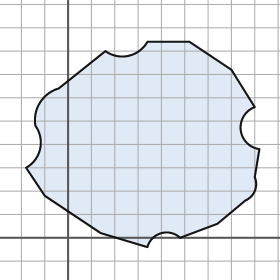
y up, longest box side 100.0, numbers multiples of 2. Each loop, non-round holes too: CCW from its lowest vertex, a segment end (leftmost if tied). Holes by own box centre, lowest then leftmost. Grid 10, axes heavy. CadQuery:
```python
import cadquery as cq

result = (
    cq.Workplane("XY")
    .moveTo(34.0, -4.0)
    .threePointArc((40.0, 2.0), (48.0, 0.0))
    .lineTo(64.0, 6.0)
    .lineTo(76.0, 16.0)
    .threePointArc((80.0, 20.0), (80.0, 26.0))
    .lineTo(82.0, 38.0)
    .threePointArc((74.0, 46.0), (80.0, 56.0))
    .lineTo(70.0, 72.0)
    .lineTo(52.0, 84.0)
    .lineTo(34.0, 84.0)
    .threePointArc((26.0, 78.0), (16.0, 80.0))
    .lineTo(-4.0, 64.0)
    .threePointArc((-12.0, 58.0), (-14.0, 48.0))
    .threePointArc((-12.0, 38.0), (-18.0, 30.0))
    .lineTo(-10.0, 18.0)
    .lineTo(14.0, 2.0)
    .close()
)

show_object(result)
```